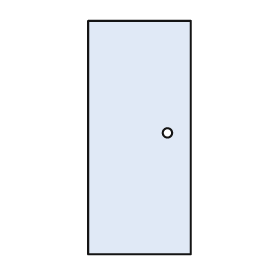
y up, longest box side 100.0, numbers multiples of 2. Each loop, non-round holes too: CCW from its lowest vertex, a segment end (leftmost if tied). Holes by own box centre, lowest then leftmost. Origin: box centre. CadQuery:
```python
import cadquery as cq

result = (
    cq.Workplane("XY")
    .moveTo(-22.0, -50.0)
    .lineTo(22.0, -50.0)
    .lineTo(22.0, 50.0)
    .lineTo(-22.0, 50.0)
    .close()
    .moveTo(12.0, 2.0)
    .circle(2.0)
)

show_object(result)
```